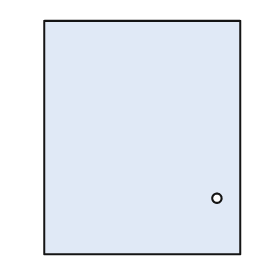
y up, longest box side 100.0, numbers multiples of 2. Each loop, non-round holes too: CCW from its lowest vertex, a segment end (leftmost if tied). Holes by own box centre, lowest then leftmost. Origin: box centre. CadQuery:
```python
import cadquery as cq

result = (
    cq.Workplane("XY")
    .moveTo(-42.0, -50.0)
    .lineTo(42.0, -50.0)
    .lineTo(42.0, 50.0)
    .lineTo(-42.0, 50.0)
    .close()
    .moveTo(32.0, -26.0)
    .circle(2.0)
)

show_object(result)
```